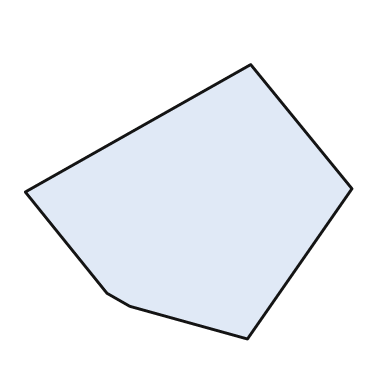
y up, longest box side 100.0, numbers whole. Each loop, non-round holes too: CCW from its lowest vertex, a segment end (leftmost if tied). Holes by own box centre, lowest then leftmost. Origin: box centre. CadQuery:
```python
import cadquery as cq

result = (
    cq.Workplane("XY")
    .moveTo(18.0, -42.0)
    .lineTo(50.0, 4.0)
    .lineTo(19.0, 42.0)
    .lineTo(-50.0, 3.0)
    .lineTo(-25.0, -28.0)
    .lineTo(-18.0, -32.0)
    .close()
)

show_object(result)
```